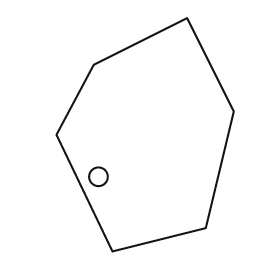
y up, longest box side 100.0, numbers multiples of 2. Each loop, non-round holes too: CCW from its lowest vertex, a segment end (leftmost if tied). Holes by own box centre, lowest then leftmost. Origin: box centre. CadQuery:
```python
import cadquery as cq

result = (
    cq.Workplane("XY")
    .moveTo(-14.0, -50.0)
    .lineTo(26.0, -40.0)
    .lineTo(38.0, 10.0)
    .lineTo(18.0, 50.0)
    .lineTo(-22.0, 30.0)
    .lineTo(-38.0, 0.0)
    .close()
    .moveTo(-20.0, -18.0)
    .circle(4.0)
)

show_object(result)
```